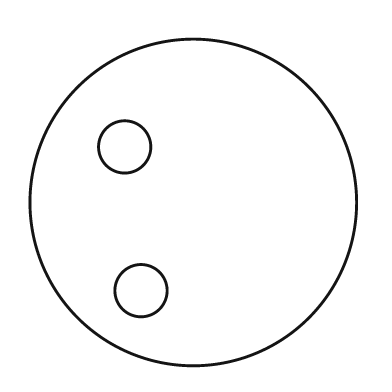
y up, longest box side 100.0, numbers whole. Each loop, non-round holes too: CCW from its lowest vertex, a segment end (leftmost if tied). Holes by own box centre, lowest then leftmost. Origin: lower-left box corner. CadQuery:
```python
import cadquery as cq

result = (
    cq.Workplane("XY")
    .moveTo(50.0, 50.0)
    .circle(50.0)
    .moveTo(34.0, 23.0)
    .circle(8.0)
    .moveTo(29.0, 67.0)
    .circle(8.0)
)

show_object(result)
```